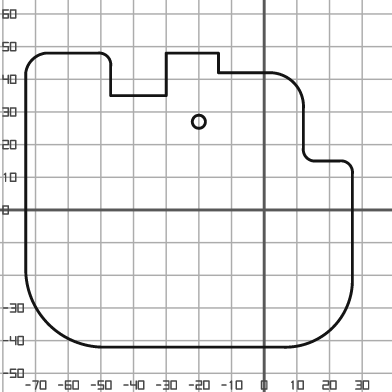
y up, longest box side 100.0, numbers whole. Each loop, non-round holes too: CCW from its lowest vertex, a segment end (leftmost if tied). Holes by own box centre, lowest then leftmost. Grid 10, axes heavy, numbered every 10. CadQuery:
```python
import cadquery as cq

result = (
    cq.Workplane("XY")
    .moveTo(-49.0, -42.0)
    .lineTo(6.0, -42.0)
    .threePointArc((21.0, -36.0), (27.0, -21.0))
    .lineTo(27.0, 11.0)
    .threePointArc((26.0, 14.0), (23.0, 15.0))
    .lineTo(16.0, 15.0)
    .threePointArc((13.0, 16.0), (12.0, 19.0))
    .lineTo(12.0, 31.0)
    .threePointArc((9.0, 39.0), (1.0, 42.0))
    .lineTo(-14.0, 42.0)
    .lineTo(-14.0, 48.0)
    .lineTo(-30.0, 48.0)
    .lineTo(-30.0, 35.0)
    .lineTo(-47.0, 35.0)
    .lineTo(-47.0, 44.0)
    .threePointArc((-48.0, 47.0), (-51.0, 48.0))
    .lineTo(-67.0, 48.0)
    .threePointArc((-71.0, 46.0), (-73.0, 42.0))
    .lineTo(-73.0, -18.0)
    .threePointArc((-66.0, -35.0), (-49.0, -42.0))
    .close()
    .moveTo(-20.0, 27.0)
    .circle(2.0)
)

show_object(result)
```